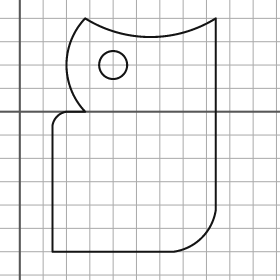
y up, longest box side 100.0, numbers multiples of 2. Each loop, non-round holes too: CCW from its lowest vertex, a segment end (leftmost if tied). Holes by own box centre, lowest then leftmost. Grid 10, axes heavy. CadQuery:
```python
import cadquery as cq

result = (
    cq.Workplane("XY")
    .moveTo(14.0, -60.0)
    .lineTo(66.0, -60.0)
    .threePointArc((78.0, -54.0), (84.0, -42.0))
    .lineTo(84.0, 40.0)
    .threePointArc((56.0, 32.0), (28.0, 40.0))
    .threePointArc((20.0, 20.0), (28.0, 0.0))
    .lineTo(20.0, 0.0)
    .threePointArc((16.0, -2.0), (14.0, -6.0))
    .close()
    .moveTo(40.0, 20.0)
    .circle(6.0)
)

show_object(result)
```